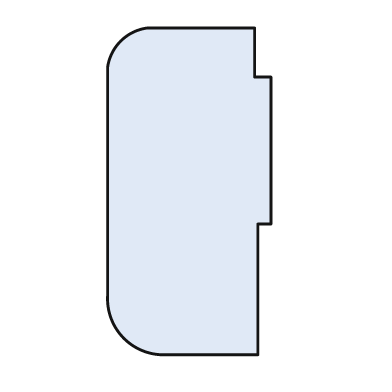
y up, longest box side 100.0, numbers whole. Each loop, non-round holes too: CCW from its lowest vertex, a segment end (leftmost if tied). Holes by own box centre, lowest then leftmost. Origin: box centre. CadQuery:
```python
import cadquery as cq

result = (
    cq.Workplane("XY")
    .moveTo(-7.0, -50.0)
    .lineTo(21.0, -50.0)
    .lineTo(21.0, -10.0)
    .lineTo(25.0, -10.0)
    .lineTo(25.0, 35.0)
    .lineTo(20.0, 35.0)
    .lineTo(20.0, 50.0)
    .lineTo(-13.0, 50.0)
    .threePointArc((-21.0, 46.0), (-25.0, 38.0))
    .lineTo(-25.0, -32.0)
    .threePointArc((-20.0, -45.0), (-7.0, -50.0))
    .close()
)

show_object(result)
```